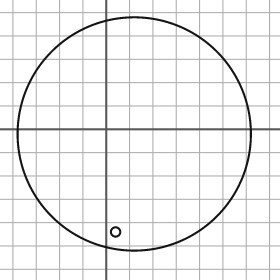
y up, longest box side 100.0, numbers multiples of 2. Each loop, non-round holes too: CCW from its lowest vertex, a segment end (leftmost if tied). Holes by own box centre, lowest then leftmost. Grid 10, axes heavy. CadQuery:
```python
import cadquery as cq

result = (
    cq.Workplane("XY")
    .moveTo(12.0, -2.0)
    .circle(50.0)
    .moveTo(4.0, -44.0)
    .circle(2.0)
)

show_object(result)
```